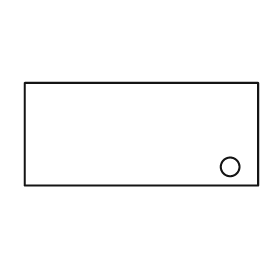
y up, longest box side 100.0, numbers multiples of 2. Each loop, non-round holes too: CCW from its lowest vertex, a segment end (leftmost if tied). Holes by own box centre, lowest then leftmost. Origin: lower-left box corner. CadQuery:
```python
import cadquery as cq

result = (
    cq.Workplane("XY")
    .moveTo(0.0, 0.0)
    .lineTo(100.0, 0.0)
    .lineTo(100.0, 44.0)
    .lineTo(0.0, 44.0)
    .close()
    .moveTo(88.0, 8.0)
    .circle(4.0)
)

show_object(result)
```